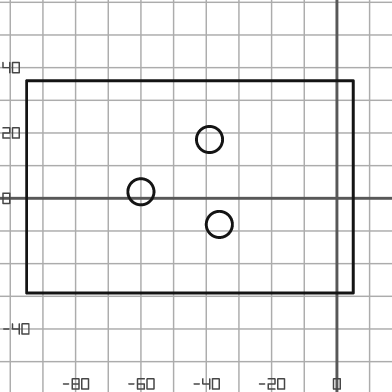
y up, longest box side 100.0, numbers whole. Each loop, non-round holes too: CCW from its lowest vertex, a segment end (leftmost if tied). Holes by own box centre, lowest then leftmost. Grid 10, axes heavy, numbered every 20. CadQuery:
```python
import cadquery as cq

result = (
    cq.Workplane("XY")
    .moveTo(-95.0, -29.0)
    .lineTo(5.0, -29.0)
    .lineTo(5.0, 36.0)
    .lineTo(-95.0, 36.0)
    .close()
    .moveTo(-36.0, -8.0)
    .circle(4.0)
    .moveTo(-60.0, 2.0)
    .circle(4.0)
    .moveTo(-39.0, 18.0)
    .circle(4.0)
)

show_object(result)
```